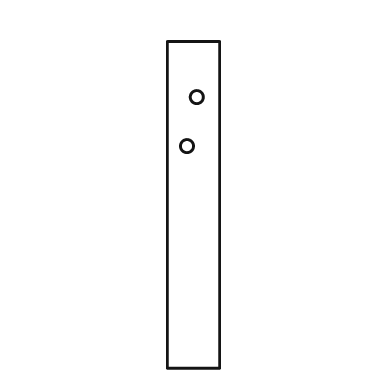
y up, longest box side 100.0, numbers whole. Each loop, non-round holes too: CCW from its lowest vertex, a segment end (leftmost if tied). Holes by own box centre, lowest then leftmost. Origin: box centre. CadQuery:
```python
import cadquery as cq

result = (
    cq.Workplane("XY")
    .moveTo(-8.0, -50.0)
    .lineTo(8.0, -50.0)
    .lineTo(8.0, 50.0)
    .lineTo(-8.0, 50.0)
    .close()
    .moveTo(-2.0, 18.0)
    .circle(2.0)
    .moveTo(1.0, 33.0)
    .circle(2.0)
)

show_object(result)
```